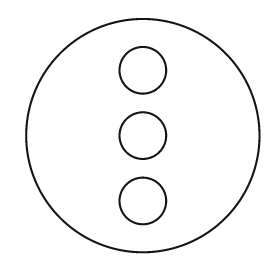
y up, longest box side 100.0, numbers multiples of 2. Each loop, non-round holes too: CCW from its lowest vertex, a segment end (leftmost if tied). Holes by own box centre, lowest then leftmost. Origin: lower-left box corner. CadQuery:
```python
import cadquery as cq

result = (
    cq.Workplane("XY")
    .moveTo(50.0, 50.0)
    .circle(50.0)
    .moveTo(50.0, 22.0)
    .circle(10.0)
    .moveTo(50.0, 50.0)
    .circle(10.0)
    .moveTo(50.0, 78.0)
    .circle(10.0)
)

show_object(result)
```